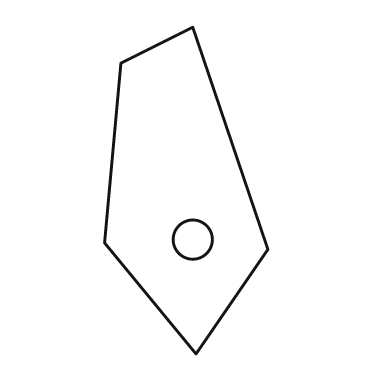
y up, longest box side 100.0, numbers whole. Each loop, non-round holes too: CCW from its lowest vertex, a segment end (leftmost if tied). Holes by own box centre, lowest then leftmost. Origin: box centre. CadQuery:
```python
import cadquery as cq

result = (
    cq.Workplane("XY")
    .moveTo(3.0, -50.0)
    .lineTo(25.0, -18.0)
    .lineTo(2.0, 50.0)
    .lineTo(-20.0, 39.0)
    .lineTo(-25.0, -16.0)
    .close()
    .moveTo(2.0, -15.0)
    .circle(6.0)
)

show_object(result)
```